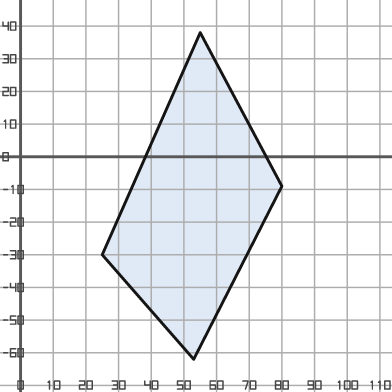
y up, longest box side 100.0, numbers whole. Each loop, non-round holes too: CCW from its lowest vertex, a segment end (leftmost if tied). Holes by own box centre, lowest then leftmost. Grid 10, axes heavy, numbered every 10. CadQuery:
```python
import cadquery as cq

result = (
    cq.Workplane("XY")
    .moveTo(53.0, -62.0)
    .lineTo(80.0, -9.0)
    .lineTo(55.0, 38.0)
    .lineTo(25.0, -30.0)
    .close()
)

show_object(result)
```